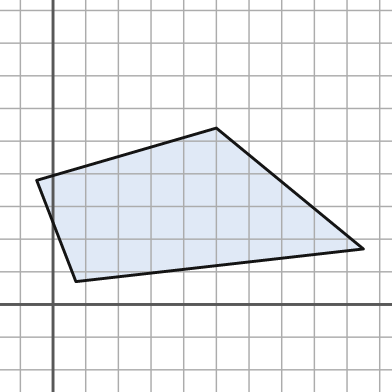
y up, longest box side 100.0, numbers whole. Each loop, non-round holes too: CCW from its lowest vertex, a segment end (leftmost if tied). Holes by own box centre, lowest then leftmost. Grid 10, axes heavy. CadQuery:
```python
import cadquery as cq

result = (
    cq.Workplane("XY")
    .moveTo(7.0, 7.0)
    .lineTo(95.0, 17.0)
    .lineTo(50.0, 54.0)
    .lineTo(-5.0, 38.0)
    .close()
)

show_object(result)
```